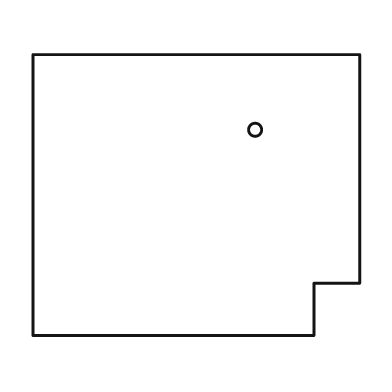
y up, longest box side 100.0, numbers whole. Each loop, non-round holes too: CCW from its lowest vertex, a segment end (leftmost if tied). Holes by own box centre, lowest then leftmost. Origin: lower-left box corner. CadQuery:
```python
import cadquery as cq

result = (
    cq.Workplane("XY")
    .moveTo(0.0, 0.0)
    .lineTo(86.0, 0.0)
    .lineTo(86.0, 16.0)
    .lineTo(100.0, 16.0)
    .lineTo(100.0, 86.0)
    .lineTo(0.0, 86.0)
    .close()
    .moveTo(68.0, 63.0)
    .circle(2.0)
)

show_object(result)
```